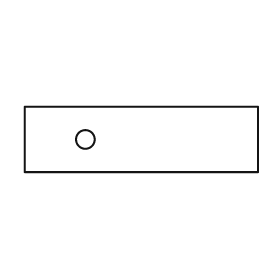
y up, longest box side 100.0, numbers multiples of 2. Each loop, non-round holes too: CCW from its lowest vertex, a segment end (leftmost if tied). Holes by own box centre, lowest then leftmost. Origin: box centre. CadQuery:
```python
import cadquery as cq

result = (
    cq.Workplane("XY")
    .moveTo(-50.0, -14.0)
    .lineTo(50.0, -14.0)
    .lineTo(50.0, 14.0)
    .lineTo(-50.0, 14.0)
    .close()
    .moveTo(-24.0, 0.0)
    .circle(4.0)
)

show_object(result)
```